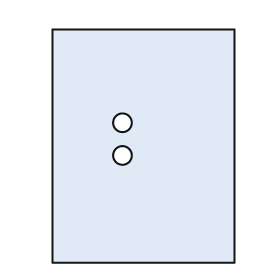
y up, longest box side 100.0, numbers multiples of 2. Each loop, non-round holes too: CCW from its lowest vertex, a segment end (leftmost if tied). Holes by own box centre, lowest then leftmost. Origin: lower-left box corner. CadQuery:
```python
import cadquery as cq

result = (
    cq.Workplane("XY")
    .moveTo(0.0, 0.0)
    .lineTo(78.0, 0.0)
    .lineTo(78.0, 100.0)
    .lineTo(0.0, 100.0)
    .close()
    .moveTo(30.0, 46.0)
    .circle(4.0)
    .moveTo(30.0, 60.0)
    .circle(4.0)
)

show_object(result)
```